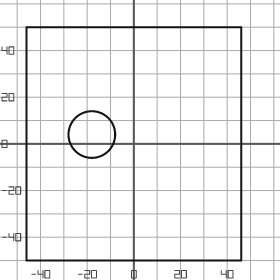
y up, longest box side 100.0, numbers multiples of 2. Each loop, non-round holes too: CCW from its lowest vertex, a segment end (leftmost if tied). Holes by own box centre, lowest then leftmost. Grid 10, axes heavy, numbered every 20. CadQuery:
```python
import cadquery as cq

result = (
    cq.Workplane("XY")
    .moveTo(-46.0, -50.0)
    .lineTo(46.0, -50.0)
    .lineTo(46.0, 50.0)
    .lineTo(-46.0, 50.0)
    .close()
    .moveTo(-18.0, 4.0)
    .circle(10.0)
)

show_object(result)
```